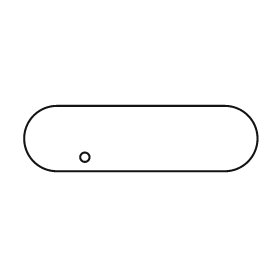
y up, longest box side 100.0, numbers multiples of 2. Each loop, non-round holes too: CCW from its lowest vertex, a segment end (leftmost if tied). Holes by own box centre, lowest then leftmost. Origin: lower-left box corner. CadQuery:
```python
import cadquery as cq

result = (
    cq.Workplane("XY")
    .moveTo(14.0, 0.0)
    .lineTo(86.0, 0.0)
    .threePointArc((100.0, 14.0), (86.0, 28.0))
    .lineTo(14.0, 28.0)
    .threePointArc((0.0, 14.0), (14.0, 0.0))
    .close()
    .moveTo(26.0, 6.0)
    .circle(2.0)
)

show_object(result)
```